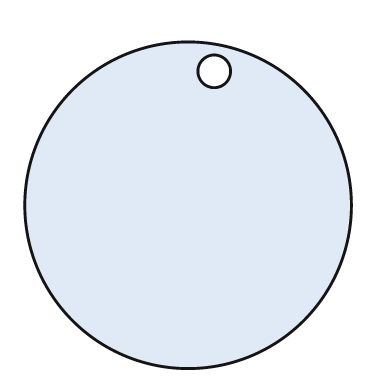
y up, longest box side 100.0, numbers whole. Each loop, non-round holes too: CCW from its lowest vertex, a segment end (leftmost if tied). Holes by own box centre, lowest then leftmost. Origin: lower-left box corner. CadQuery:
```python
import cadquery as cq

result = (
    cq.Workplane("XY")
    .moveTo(50.0, 50.0)
    .circle(50.0)
    .moveTo(58.0, 91.0)
    .circle(5.0)
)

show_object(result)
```